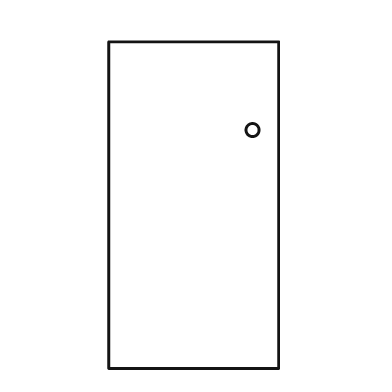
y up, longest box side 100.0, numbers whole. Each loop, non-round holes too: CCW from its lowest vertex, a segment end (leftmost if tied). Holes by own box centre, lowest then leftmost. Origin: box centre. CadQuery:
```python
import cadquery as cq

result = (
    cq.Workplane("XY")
    .moveTo(-26.0, -50.0)
    .lineTo(26.0, -50.0)
    .lineTo(26.0, 50.0)
    .lineTo(-26.0, 50.0)
    .close()
    .moveTo(18.0, 23.0)
    .circle(2.0)
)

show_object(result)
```